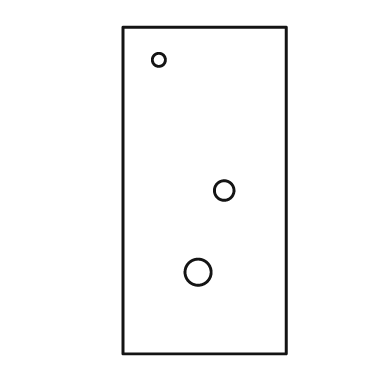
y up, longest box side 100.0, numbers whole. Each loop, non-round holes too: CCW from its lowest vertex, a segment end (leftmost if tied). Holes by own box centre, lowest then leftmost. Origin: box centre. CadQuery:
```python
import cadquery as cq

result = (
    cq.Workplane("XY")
    .moveTo(-25.0, -50.0)
    .lineTo(25.0, -50.0)
    .lineTo(25.0, 50.0)
    .lineTo(-25.0, 50.0)
    .close()
    .moveTo(-2.0, -25.0)
    .circle(4.0)
    .moveTo(6.0, 0.0)
    .circle(3.0)
    .moveTo(-14.0, 40.0)
    .circle(2.0)
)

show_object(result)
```